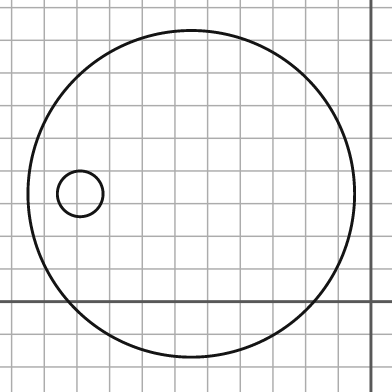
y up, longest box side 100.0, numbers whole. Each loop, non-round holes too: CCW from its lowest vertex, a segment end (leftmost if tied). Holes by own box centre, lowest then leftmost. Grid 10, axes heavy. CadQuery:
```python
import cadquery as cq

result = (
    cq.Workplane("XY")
    .moveTo(-55.0, 33.0)
    .circle(50.0)
    .moveTo(-89.0, 33.0)
    .circle(7.0)
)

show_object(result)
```